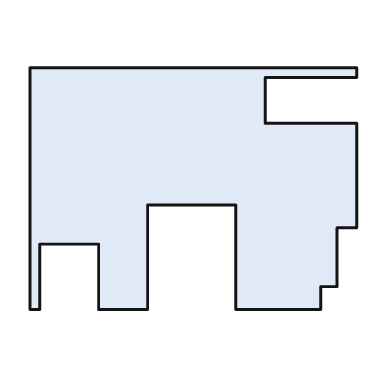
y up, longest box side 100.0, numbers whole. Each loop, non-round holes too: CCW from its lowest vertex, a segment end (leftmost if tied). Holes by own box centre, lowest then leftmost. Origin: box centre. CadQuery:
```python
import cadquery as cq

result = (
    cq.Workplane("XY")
    .moveTo(-50.0, -37.0)
    .lineTo(-47.0, -37.0)
    .lineTo(-47.0, -17.0)
    .lineTo(-29.0, -17.0)
    .lineTo(-29.0, -37.0)
    .lineTo(-14.0, -37.0)
    .lineTo(-14.0, -5.0)
    .lineTo(13.0, -5.0)
    .lineTo(13.0, -37.0)
    .lineTo(39.0, -37.0)
    .lineTo(39.0, -30.0)
    .lineTo(44.0, -30.0)
    .lineTo(44.0, -12.0)
    .lineTo(50.0, -12.0)
    .lineTo(50.0, 20.0)
    .lineTo(22.0, 20.0)
    .lineTo(22.0, 34.0)
    .lineTo(50.0, 34.0)
    .lineTo(50.0, 37.0)
    .lineTo(-50.0, 37.0)
    .close()
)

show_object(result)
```